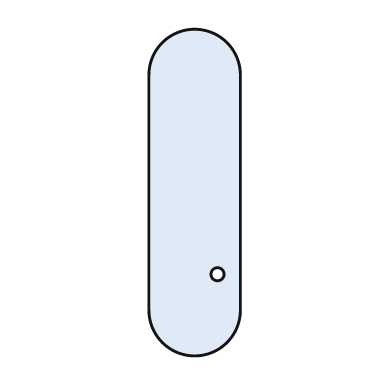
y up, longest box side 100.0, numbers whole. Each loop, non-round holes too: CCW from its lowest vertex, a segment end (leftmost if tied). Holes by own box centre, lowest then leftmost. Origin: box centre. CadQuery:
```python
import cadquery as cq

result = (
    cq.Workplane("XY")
    .moveTo(-14.0, -36.0)
    .threePointArc((0.0, -50.0), (14.0, -36.0))
    .lineTo(14.0, 36.0)
    .threePointArc((0.0, 50.0), (-14.0, 36.0))
    .close()
    .moveTo(7.0, -25.0)
    .circle(2.0)
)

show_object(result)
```